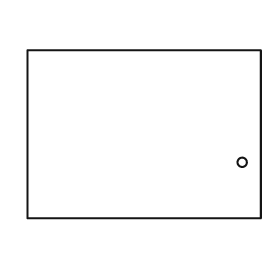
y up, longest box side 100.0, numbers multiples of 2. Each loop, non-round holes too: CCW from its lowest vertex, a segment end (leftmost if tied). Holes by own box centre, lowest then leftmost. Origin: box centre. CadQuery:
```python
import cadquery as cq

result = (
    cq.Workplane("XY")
    .moveTo(-50.0, -36.0)
    .lineTo(50.0, -36.0)
    .lineTo(50.0, 36.0)
    .lineTo(-50.0, 36.0)
    .close()
    .moveTo(42.0, -12.0)
    .circle(2.0)
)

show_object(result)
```